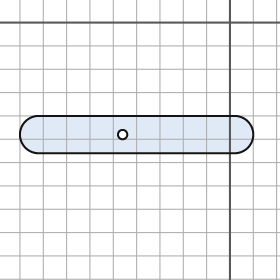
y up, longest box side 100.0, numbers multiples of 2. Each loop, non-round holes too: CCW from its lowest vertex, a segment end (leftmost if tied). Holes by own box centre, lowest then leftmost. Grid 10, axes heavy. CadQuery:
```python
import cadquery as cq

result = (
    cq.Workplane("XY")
    .moveTo(-82.0, -56.0)
    .lineTo(2.0, -56.0)
    .threePointArc((10.0, -48.0), (2.0, -40.0))
    .lineTo(-82.0, -40.0)
    .threePointArc((-90.0, -48.0), (-82.0, -56.0))
    .close()
    .moveTo(-46.0, -48.0)
    .circle(2.0)
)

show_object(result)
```